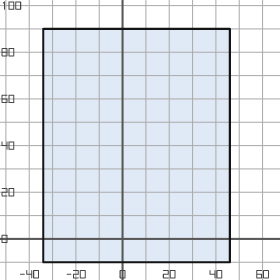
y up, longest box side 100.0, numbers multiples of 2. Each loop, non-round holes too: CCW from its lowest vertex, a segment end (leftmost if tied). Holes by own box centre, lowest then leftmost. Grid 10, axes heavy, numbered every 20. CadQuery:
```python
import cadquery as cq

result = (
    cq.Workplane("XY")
    .moveTo(-34.0, -10.0)
    .lineTo(46.0, -10.0)
    .lineTo(46.0, 90.0)
    .lineTo(-34.0, 90.0)
    .close()
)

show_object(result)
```